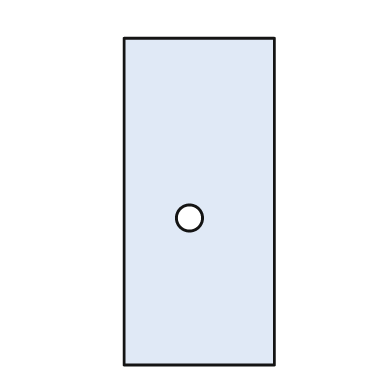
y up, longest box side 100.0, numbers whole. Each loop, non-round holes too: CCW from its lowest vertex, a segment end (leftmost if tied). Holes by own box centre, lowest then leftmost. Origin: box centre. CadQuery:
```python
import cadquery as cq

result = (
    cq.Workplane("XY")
    .moveTo(-23.0, -50.0)
    .lineTo(23.0, -50.0)
    .lineTo(23.0, 50.0)
    .lineTo(-23.0, 50.0)
    .close()
    .moveTo(-3.0, -5.0)
    .circle(4.0)
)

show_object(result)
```